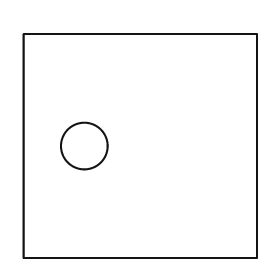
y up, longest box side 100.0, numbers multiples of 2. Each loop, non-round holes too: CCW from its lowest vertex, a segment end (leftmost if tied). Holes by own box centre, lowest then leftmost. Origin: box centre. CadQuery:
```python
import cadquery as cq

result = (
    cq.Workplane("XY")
    .moveTo(-50.0, -48.0)
    .lineTo(50.0, -48.0)
    .lineTo(50.0, 48.0)
    .lineTo(-50.0, 48.0)
    .close()
    .moveTo(-24.0, 0.0)
    .circle(10.0)
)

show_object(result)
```